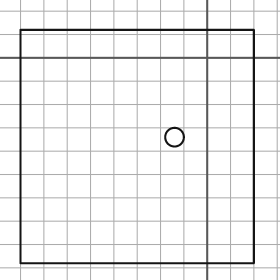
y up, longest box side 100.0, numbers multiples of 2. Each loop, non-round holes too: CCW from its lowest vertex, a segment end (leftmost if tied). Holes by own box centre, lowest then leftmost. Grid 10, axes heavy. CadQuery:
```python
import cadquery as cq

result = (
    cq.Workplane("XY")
    .moveTo(-80.0, -88.0)
    .lineTo(20.0, -88.0)
    .lineTo(20.0, 12.0)
    .lineTo(-80.0, 12.0)
    .close()
    .moveTo(-14.0, -34.0)
    .circle(4.0)
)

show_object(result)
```